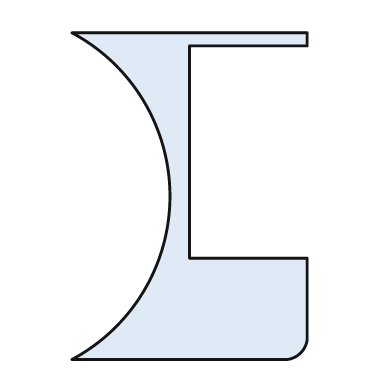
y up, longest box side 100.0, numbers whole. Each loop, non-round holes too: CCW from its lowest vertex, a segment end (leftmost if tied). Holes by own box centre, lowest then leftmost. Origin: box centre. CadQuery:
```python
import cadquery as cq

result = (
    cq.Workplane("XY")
    .moveTo(-36.0, -50.0)
    .lineTo(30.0, -50.0)
    .threePointArc((34.0, -48.0), (36.0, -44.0))
    .lineTo(36.0, -19.0)
    .lineTo(0.0, -19.0)
    .lineTo(0.0, 46.0)
    .lineTo(36.0, 46.0)
    .lineTo(36.0, 50.0)
    .lineTo(-36.0, 50.0)
    .threePointArc((-6.0, 0.0), (-36.0, -50.0))
    .close()
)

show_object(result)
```